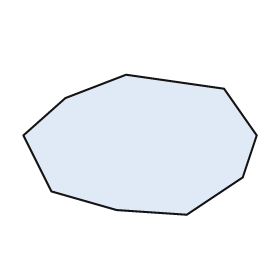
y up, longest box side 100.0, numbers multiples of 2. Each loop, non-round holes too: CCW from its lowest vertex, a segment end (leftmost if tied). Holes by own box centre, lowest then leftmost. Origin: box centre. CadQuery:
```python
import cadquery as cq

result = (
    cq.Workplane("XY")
    .moveTo(20.0, -30.0)
    .lineTo(44.0, -14.0)
    .lineTo(50.0, 4.0)
    .lineTo(36.0, 24.0)
    .lineTo(-6.0, 30.0)
    .lineTo(-32.0, 20.0)
    .lineTo(-50.0, 4.0)
    .lineTo(-38.0, -20.0)
    .lineTo(-10.0, -28.0)
    .close()
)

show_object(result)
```